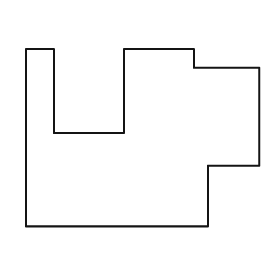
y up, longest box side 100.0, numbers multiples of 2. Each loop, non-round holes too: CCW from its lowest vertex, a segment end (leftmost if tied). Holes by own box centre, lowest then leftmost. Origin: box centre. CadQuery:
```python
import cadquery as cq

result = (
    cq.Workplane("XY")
    .moveTo(-50.0, -38.0)
    .lineTo(28.0, -38.0)
    .lineTo(28.0, -12.0)
    .lineTo(50.0, -12.0)
    .lineTo(50.0, 30.0)
    .lineTo(22.0, 30.0)
    .lineTo(22.0, 38.0)
    .lineTo(-8.0, 38.0)
    .lineTo(-8.0, 2.0)
    .lineTo(-38.0, 2.0)
    .lineTo(-38.0, 38.0)
    .lineTo(-50.0, 38.0)
    .close()
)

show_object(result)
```